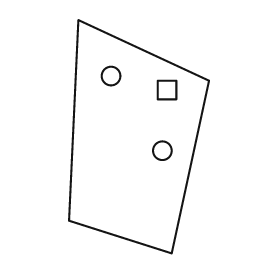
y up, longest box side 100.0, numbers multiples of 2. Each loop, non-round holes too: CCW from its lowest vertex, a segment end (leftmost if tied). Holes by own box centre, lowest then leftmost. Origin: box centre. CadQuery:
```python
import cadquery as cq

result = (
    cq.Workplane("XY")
    .moveTo(14.0, -50.0)
    .lineTo(30.0, 24.0)
    .lineTo(-26.0, 50.0)
    .lineTo(-30.0, -36.0)
    .close()
    .moveTo(10.0, -6.0)
    .circle(4.0)
    .moveTo(8.0, 16.0)
    .lineTo(16.0, 16.0)
    .lineTo(16.0, 24.0)
    .lineTo(8.0, 24.0)
    .close()
    .moveTo(-12.0, 26.0)
    .circle(4.0)
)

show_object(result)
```